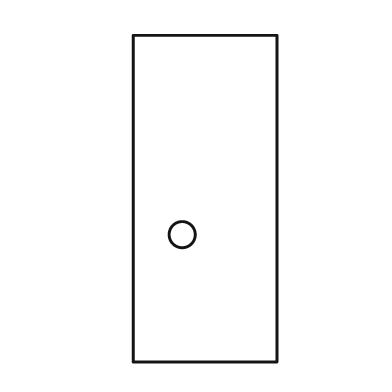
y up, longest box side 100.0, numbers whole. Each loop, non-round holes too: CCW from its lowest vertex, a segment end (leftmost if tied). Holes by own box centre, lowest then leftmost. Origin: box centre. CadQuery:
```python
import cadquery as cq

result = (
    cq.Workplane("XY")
    .moveTo(-22.0, -50.0)
    .lineTo(22.0, -50.0)
    .lineTo(22.0, 50.0)
    .lineTo(-22.0, 50.0)
    .close()
    .moveTo(-7.0, -11.0)
    .circle(4.0)
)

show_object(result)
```